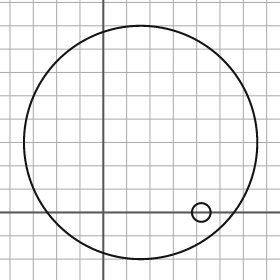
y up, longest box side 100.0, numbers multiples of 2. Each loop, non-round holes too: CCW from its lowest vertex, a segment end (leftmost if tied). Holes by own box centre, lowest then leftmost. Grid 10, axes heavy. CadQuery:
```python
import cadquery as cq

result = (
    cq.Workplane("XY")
    .moveTo(16.0, 30.0)
    .circle(50.0)
    .moveTo(42.0, 0.0)
    .circle(4.0)
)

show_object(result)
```